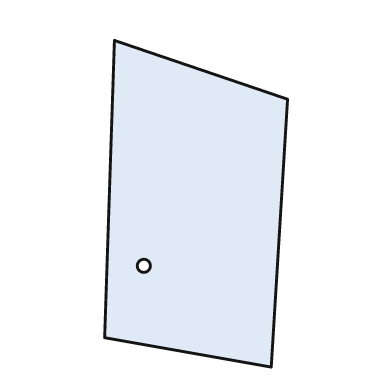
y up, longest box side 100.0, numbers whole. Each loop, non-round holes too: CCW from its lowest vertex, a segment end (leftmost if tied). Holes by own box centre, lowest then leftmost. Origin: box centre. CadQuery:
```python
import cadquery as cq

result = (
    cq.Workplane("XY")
    .moveTo(23.0, -50.0)
    .lineTo(28.0, 32.0)
    .lineTo(-25.0, 50.0)
    .lineTo(-28.0, -41.0)
    .close()
    .moveTo(-16.0, -19.0)
    .circle(2.0)
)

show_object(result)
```